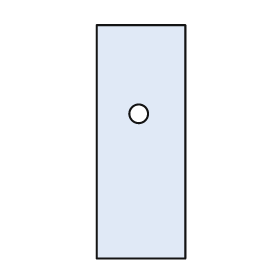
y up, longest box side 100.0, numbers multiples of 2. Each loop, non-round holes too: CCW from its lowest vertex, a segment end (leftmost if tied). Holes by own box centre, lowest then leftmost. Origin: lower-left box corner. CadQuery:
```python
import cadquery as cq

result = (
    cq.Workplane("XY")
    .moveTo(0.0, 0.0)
    .lineTo(38.0, 0.0)
    .lineTo(38.0, 100.0)
    .lineTo(0.0, 100.0)
    .close()
    .moveTo(18.0, 62.0)
    .circle(4.0)
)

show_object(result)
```